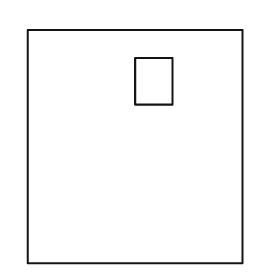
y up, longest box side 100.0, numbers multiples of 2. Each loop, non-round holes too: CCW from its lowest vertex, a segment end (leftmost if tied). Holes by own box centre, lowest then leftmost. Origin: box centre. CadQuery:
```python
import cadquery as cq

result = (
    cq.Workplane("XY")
    .moveTo(-46.0, -50.0)
    .lineTo(46.0, -50.0)
    .lineTo(46.0, 50.0)
    .lineTo(-46.0, 50.0)
    .close()
    .moveTo(0.0, 18.0)
    .lineTo(16.0, 18.0)
    .lineTo(16.0, 38.0)
    .lineTo(0.0, 38.0)
    .close()
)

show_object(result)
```